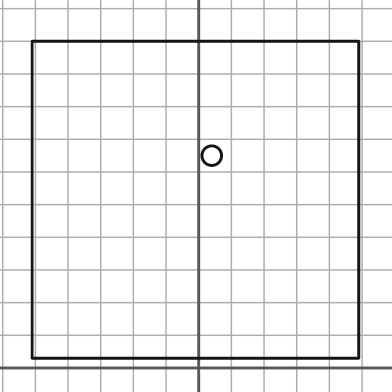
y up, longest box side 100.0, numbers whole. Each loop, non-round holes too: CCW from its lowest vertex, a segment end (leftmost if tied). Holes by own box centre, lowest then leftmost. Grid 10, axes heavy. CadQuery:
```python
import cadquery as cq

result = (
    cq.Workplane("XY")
    .moveTo(-51.0, 3.0)
    .lineTo(49.0, 3.0)
    .lineTo(49.0, 100.0)
    .lineTo(-51.0, 100.0)
    .close()
    .moveTo(4.0, 65.0)
    .circle(3.0)
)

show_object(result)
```